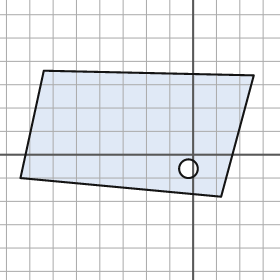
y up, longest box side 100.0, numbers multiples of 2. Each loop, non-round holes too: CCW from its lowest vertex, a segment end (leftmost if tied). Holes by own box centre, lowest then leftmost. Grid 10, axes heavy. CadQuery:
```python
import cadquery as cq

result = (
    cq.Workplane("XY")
    .moveTo(12.0, -18.0)
    .lineTo(26.0, 34.0)
    .lineTo(-64.0, 36.0)
    .lineTo(-74.0, -10.0)
    .close()
    .moveTo(-2.0, -6.0)
    .circle(4.0)
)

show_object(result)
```